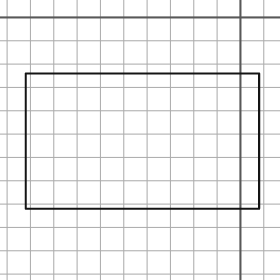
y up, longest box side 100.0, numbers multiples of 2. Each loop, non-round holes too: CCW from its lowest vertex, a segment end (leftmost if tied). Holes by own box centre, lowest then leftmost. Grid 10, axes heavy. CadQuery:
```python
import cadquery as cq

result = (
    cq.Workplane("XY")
    .moveTo(-92.0, -82.0)
    .lineTo(8.0, -82.0)
    .lineTo(8.0, -24.0)
    .lineTo(-92.0, -24.0)
    .close()
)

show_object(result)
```